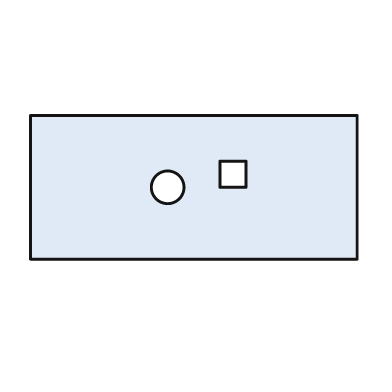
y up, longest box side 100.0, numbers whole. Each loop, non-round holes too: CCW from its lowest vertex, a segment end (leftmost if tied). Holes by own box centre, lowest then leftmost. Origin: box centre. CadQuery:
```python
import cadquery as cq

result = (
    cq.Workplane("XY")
    .moveTo(-50.0, -22.0)
    .lineTo(50.0, -22.0)
    .lineTo(50.0, 22.0)
    .lineTo(-50.0, 22.0)
    .close()
    .moveTo(-8.0, 0.0)
    .circle(5.0)
    .moveTo(8.0, 0.0)
    .lineTo(16.0, 0.0)
    .lineTo(16.0, 8.0)
    .lineTo(8.0, 8.0)
    .close()
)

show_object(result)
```